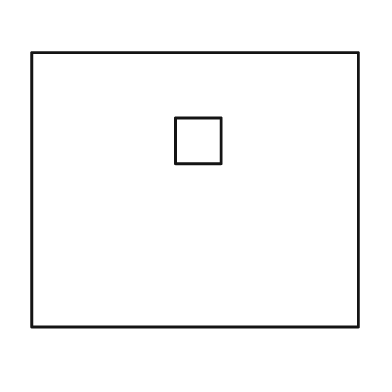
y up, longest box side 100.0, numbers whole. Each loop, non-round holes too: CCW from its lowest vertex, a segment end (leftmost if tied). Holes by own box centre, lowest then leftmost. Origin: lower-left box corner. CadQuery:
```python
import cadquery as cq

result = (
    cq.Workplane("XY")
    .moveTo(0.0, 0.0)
    .lineTo(100.0, 0.0)
    .lineTo(100.0, 84.0)
    .lineTo(0.0, 84.0)
    .close()
    .moveTo(44.0, 50.0)
    .lineTo(58.0, 50.0)
    .lineTo(58.0, 64.0)
    .lineTo(44.0, 64.0)
    .close()
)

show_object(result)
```